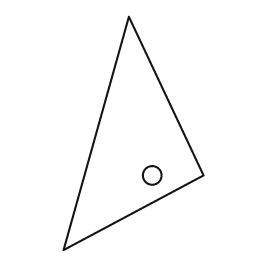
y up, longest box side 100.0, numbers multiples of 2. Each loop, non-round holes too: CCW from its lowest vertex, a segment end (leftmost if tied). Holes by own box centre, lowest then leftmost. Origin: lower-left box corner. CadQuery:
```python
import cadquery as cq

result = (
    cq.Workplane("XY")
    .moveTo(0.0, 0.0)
    .lineTo(60.0, 32.0)
    .lineTo(28.0, 100.0)
    .close()
    .moveTo(38.0, 32.0)
    .circle(4.0)
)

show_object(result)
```